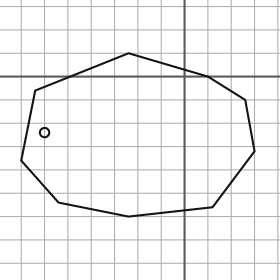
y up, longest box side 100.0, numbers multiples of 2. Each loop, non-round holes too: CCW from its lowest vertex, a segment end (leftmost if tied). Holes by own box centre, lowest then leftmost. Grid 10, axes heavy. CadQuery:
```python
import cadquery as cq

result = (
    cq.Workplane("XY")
    .moveTo(-24.0, -60.0)
    .lineTo(12.0, -56.0)
    .lineTo(30.0, -32.0)
    .lineTo(26.0, -10.0)
    .lineTo(10.0, 0.0)
    .lineTo(-24.0, 10.0)
    .lineTo(-64.0, -6.0)
    .lineTo(-70.0, -36.0)
    .lineTo(-54.0, -54.0)
    .close()
    .moveTo(-60.0, -24.0)
    .circle(2.0)
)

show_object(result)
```